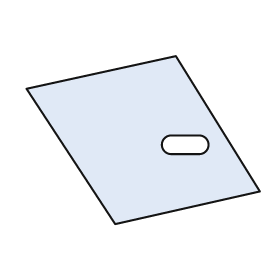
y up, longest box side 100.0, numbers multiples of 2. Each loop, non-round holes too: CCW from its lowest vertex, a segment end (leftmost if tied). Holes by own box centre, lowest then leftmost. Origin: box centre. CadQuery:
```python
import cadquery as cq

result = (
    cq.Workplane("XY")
    .moveTo(-12.0, -36.0)
    .lineTo(50.0, -22.0)
    .lineTo(14.0, 36.0)
    .lineTo(-50.0, 22.0)
    .close()
    .moveTo(12.0, -6.0)
    .lineTo(24.0, -6.0)
    .threePointArc((28.0, -2.0), (24.0, 2.0))
    .lineTo(12.0, 2.0)
    .threePointArc((8.0, -2.0), (12.0, -6.0))
    .close()
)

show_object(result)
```